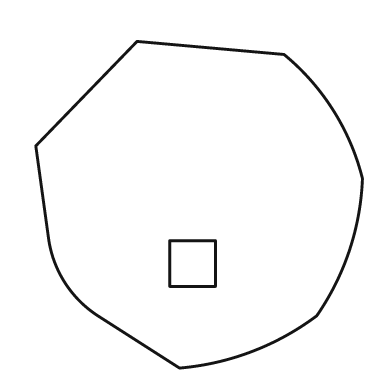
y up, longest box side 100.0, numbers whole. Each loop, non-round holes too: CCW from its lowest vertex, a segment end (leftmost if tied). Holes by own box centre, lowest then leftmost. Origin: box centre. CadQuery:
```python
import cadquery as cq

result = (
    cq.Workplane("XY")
    .moveTo(-6.0, -50.0)
    .threePointArc((16.0, -45.0), (36.0, -34.0))
    .threePointArc((46.0, -14.0), (50.0, 8.0))
    .threePointArc((41.0, 29.0), (26.0, 46.0))
    .lineTo(-19.0, 50.0)
    .lineTo(-50.0, 18.0)
    .lineTo(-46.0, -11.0)
    .threePointArc((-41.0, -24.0), (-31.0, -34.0))
    .close()
    .moveTo(-9.0, -25.0)
    .lineTo(5.0, -25.0)
    .lineTo(5.0, -11.0)
    .lineTo(-9.0, -11.0)
    .close()
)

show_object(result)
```